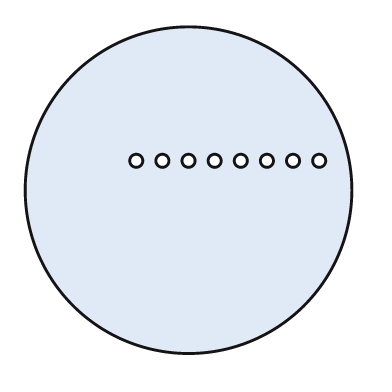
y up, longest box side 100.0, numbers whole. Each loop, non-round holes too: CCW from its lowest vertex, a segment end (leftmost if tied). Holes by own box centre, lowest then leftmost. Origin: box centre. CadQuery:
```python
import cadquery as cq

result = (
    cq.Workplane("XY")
    .moveTo(0.0, 0.0)
    .circle(50.0)
    .moveTo(-16.0, 9.0)
    .circle(2.0)
    .moveTo(-8.0, 9.0)
    .circle(2.0)
    .moveTo(0.0, 9.0)
    .circle(2.0)
    .moveTo(8.0, 9.0)
    .circle(2.0)
    .moveTo(16.0, 9.0)
    .circle(2.0)
    .moveTo(24.0, 9.0)
    .circle(2.0)
    .moveTo(32.0, 9.0)
    .circle(2.0)
    .moveTo(40.0, 9.0)
    .circle(2.0)
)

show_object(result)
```